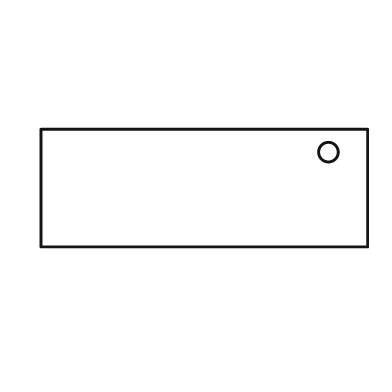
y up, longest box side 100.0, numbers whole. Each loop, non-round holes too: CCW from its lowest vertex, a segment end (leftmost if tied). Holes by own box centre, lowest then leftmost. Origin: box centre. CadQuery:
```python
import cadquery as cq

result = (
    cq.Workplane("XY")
    .moveTo(-50.0, -18.0)
    .lineTo(50.0, -18.0)
    .lineTo(50.0, 18.0)
    .lineTo(-50.0, 18.0)
    .close()
    .moveTo(38.0, 11.0)
    .circle(3.0)
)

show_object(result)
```